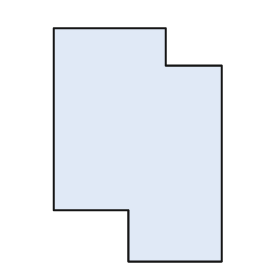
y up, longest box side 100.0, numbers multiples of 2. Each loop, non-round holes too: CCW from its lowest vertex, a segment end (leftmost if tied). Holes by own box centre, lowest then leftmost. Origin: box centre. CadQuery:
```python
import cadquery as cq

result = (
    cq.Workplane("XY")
    .moveTo(-4.0, -50.0)
    .lineTo(36.0, -50.0)
    .lineTo(36.0, 34.0)
    .lineTo(12.0, 34.0)
    .lineTo(12.0, 50.0)
    .lineTo(-36.0, 50.0)
    .lineTo(-36.0, -28.0)
    .lineTo(-4.0, -28.0)
    .close()
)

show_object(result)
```